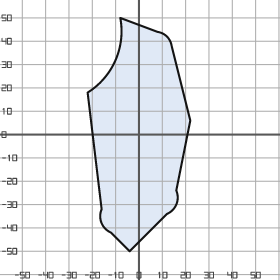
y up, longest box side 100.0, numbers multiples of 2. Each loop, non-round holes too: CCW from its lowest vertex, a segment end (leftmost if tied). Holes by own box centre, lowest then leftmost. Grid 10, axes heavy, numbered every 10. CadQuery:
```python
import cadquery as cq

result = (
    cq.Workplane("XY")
    .moveTo(-4.0, -50.0)
    .lineTo(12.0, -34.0)
    .threePointArc((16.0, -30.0), (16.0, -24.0))
    .lineTo(22.0, 6.0)
    .lineTo(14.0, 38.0)
    .threePointArc((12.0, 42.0), (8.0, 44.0))
    .lineTo(-8.0, 50.0)
    .threePointArc((-10.0, 32.0), (-22.0, 18.0))
    .lineTo(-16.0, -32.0)
    .threePointArc((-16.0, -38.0), (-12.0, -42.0))
    .close()
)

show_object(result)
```